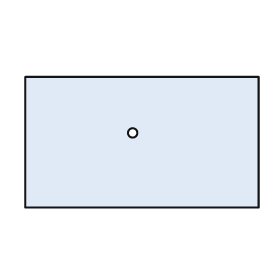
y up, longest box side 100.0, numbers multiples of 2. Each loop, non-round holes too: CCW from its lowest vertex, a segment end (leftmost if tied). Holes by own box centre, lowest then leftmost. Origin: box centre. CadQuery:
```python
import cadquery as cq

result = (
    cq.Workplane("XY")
    .moveTo(-50.0, -28.0)
    .lineTo(50.0, -28.0)
    .lineTo(50.0, 28.0)
    .lineTo(-50.0, 28.0)
    .close()
    .moveTo(-4.0, 4.0)
    .circle(2.0)
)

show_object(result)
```